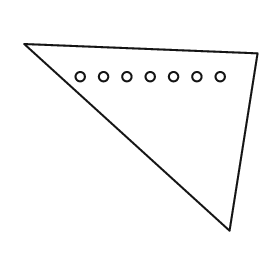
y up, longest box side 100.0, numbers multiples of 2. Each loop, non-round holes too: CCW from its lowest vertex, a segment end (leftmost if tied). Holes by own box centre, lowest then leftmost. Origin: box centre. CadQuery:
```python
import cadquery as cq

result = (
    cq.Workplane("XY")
    .moveTo(38.0, -40.0)
    .lineTo(50.0, 36.0)
    .lineTo(-50.0, 40.0)
    .close()
    .moveTo(-26.0, 26.0)
    .circle(2.0)
    .moveTo(-16.0, 26.0)
    .circle(2.0)
    .moveTo(-6.0, 26.0)
    .circle(2.0)
    .moveTo(4.0, 26.0)
    .circle(2.0)
    .moveTo(14.0, 26.0)
    .circle(2.0)
    .moveTo(24.0, 26.0)
    .circle(2.0)
    .moveTo(34.0, 26.0)
    .circle(2.0)
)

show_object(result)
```